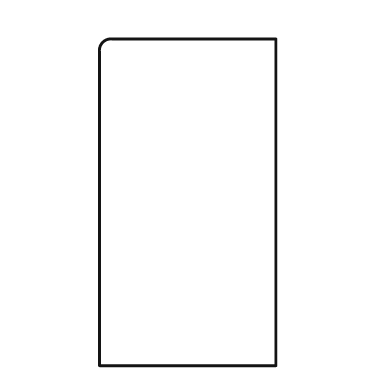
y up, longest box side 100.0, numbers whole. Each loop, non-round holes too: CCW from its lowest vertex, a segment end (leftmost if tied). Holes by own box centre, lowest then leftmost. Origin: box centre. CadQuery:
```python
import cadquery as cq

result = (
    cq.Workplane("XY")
    .moveTo(-27.0, -50.0)
    .lineTo(27.0, -50.0)
    .lineTo(27.0, 50.0)
    .lineTo(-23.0, 50.0)
    .threePointArc((-26.0, 49.0), (-27.0, 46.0))
    .close()
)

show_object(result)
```